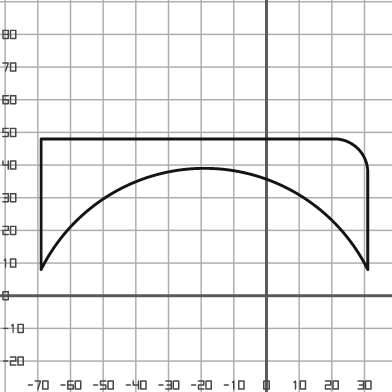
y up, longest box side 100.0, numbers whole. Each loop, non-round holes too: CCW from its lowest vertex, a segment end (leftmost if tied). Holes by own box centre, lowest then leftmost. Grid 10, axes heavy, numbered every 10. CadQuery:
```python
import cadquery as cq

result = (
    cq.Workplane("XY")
    .moveTo(-69.0, 8.0)
    .threePointArc((-19.0, 39.0), (31.0, 8.0))
    .lineTo(31.0, 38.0)
    .threePointArc((28.0, 45.0), (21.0, 48.0))
    .lineTo(-69.0, 48.0)
    .close()
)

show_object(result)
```